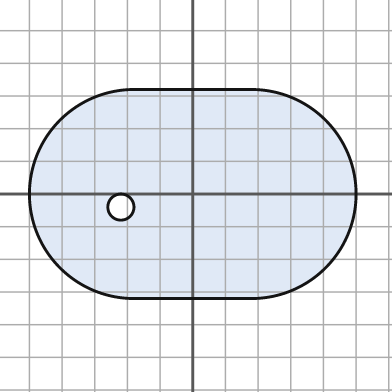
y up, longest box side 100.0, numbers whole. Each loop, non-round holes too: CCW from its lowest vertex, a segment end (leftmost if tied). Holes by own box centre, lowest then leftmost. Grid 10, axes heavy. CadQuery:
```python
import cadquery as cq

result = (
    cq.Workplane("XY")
    .moveTo(-18.0, -32.0)
    .lineTo(18.0, -32.0)
    .threePointArc((50.0, 0.0), (18.0, 32.0))
    .lineTo(-18.0, 32.0)
    .threePointArc((-50.0, 0.0), (-18.0, -32.0))
    .close()
    .moveTo(-22.0, -4.0)
    .circle(4.0)
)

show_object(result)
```